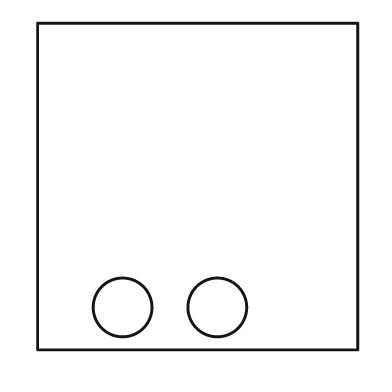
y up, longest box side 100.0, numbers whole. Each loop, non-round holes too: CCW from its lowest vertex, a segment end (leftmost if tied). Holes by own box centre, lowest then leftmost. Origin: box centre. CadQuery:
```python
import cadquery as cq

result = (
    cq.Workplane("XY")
    .moveTo(-49.0, -50.0)
    .lineTo(49.0, -50.0)
    .lineTo(49.0, 50.0)
    .lineTo(-49.0, 50.0)
    .close()
    .moveTo(-23.0, -37.0)
    .circle(9.0)
    .moveTo(6.0, -37.0)
    .circle(9.0)
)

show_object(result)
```